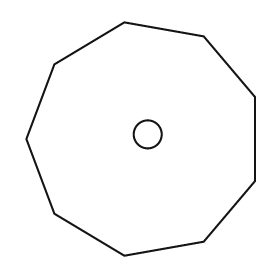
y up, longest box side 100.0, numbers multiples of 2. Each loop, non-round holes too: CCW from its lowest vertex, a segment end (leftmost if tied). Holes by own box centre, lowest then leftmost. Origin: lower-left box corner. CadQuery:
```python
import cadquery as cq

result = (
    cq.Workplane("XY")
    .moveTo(42.0, 0.0)
    .lineTo(76.0, 6.0)
    .lineTo(98.0, 32.0)
    .lineTo(98.0, 68.0)
    .lineTo(76.0, 94.0)
    .lineTo(42.0, 100.0)
    .lineTo(12.0, 82.0)
    .lineTo(0.0, 50.0)
    .lineTo(12.0, 18.0)
    .close()
    .moveTo(52.0, 52.0)
    .circle(6.0)
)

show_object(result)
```